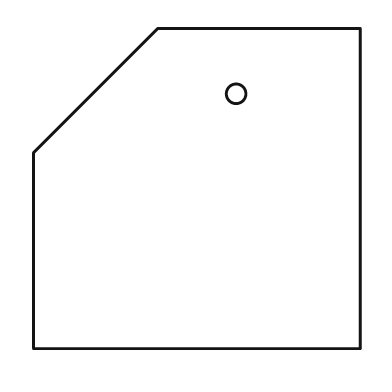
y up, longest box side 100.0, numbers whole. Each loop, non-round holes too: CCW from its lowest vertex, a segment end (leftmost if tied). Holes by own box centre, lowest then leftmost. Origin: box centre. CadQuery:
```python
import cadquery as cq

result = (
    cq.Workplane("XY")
    .moveTo(-50.0, -49.0)
    .lineTo(50.0, -49.0)
    .lineTo(50.0, 49.0)
    .lineTo(-12.0, 49.0)
    .lineTo(-50.0, 11.0)
    .close()
    .moveTo(12.0, 29.0)
    .circle(3.0)
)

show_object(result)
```